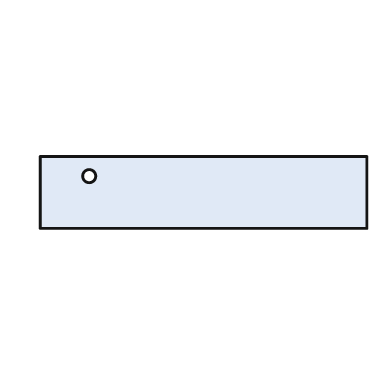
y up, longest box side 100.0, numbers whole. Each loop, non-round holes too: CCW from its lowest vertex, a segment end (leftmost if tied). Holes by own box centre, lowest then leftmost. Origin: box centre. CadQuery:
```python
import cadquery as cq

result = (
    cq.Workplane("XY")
    .moveTo(-50.0, -11.0)
    .lineTo(50.0, -11.0)
    .lineTo(50.0, 11.0)
    .lineTo(-50.0, 11.0)
    .close()
    .moveTo(-35.0, 5.0)
    .circle(2.0)
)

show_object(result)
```